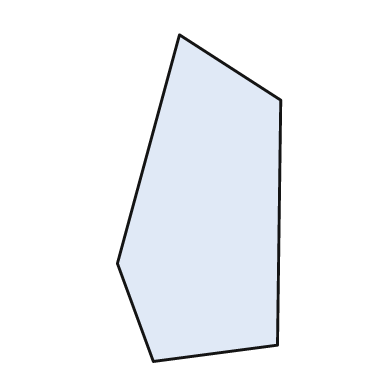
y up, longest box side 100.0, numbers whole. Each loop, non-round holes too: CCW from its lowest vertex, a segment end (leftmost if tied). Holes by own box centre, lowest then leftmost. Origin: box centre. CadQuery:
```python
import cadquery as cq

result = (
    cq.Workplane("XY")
    .moveTo(-14.0, -50.0)
    .lineTo(24.0, -45.0)
    .lineTo(25.0, 30.0)
    .lineTo(-6.0, 50.0)
    .lineTo(-25.0, -20.0)
    .close()
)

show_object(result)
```